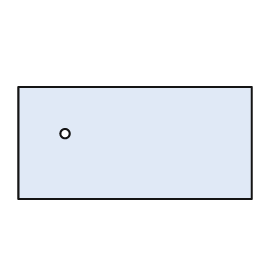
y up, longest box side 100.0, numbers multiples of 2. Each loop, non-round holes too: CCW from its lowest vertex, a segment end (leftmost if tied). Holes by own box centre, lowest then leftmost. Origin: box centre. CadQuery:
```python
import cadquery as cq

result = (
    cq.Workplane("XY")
    .moveTo(-50.0, -24.0)
    .lineTo(50.0, -24.0)
    .lineTo(50.0, 24.0)
    .lineTo(-50.0, 24.0)
    .close()
    .moveTo(-30.0, 4.0)
    .circle(2.0)
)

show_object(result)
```